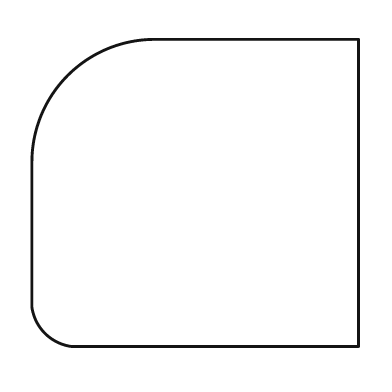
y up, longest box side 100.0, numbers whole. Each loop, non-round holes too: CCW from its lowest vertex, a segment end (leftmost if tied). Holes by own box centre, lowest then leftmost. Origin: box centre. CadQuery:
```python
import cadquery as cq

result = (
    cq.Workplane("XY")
    .moveTo(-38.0, -47.0)
    .lineTo(50.0, -47.0)
    .lineTo(50.0, 47.0)
    .lineTo(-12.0, 47.0)
    .threePointArc((-39.0, 36.0), (-50.0, 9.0))
    .lineTo(-50.0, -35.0)
    .threePointArc((-46.0, -43.0), (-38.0, -47.0))
    .close()
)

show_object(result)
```